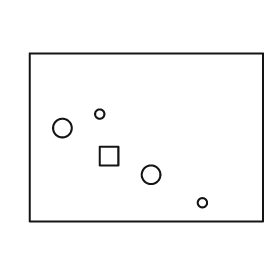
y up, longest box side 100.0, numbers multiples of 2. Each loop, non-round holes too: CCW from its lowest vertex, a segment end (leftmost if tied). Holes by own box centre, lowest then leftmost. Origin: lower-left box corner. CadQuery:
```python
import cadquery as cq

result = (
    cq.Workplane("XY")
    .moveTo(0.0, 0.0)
    .lineTo(100.0, 0.0)
    .lineTo(100.0, 72.0)
    .lineTo(0.0, 72.0)
    .close()
    .moveTo(74.0, 8.0)
    .circle(2.0)
    .moveTo(52.0, 20.0)
    .circle(4.0)
    .moveTo(30.0, 24.0)
    .lineTo(38.0, 24.0)
    .lineTo(38.0, 32.0)
    .lineTo(30.0, 32.0)
    .close()
    .moveTo(14.0, 40.0)
    .circle(4.0)
    .moveTo(30.0, 46.0)
    .circle(2.0)
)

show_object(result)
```